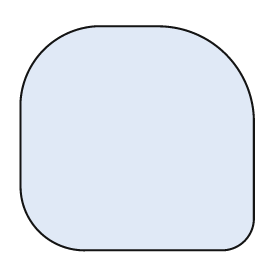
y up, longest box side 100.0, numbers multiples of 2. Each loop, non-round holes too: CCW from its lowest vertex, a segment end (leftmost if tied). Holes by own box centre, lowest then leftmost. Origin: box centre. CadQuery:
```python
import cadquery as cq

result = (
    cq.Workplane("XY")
    .moveTo(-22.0, -48.0)
    .lineTo(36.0, -48.0)
    .threePointArc((46.0, -44.0), (50.0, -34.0))
    .lineTo(50.0, 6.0)
    .threePointArc((38.0, 36.0), (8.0, 48.0))
    .lineTo(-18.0, 48.0)
    .threePointArc((-40.0, 38.0), (-50.0, 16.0))
    .lineTo(-50.0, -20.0)
    .threePointArc((-42.0, -40.0), (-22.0, -48.0))
    .close()
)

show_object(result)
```